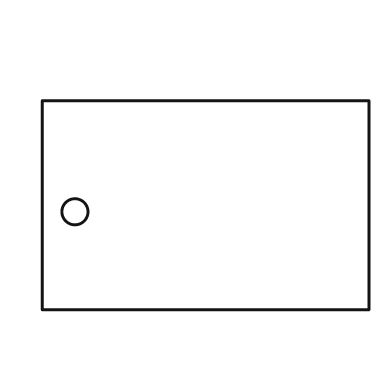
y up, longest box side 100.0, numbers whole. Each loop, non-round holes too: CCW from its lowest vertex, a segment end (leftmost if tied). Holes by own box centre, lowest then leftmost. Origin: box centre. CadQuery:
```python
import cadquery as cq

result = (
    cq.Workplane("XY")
    .moveTo(-50.0, -32.0)
    .lineTo(50.0, -32.0)
    .lineTo(50.0, 32.0)
    .lineTo(-50.0, 32.0)
    .close()
    .moveTo(-40.0, -2.0)
    .circle(4.0)
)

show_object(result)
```